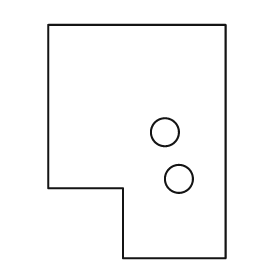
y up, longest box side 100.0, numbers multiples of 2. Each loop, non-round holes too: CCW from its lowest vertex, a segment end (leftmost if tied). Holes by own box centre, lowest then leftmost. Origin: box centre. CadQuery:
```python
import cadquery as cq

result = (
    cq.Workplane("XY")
    .moveTo(-6.0, -50.0)
    .lineTo(38.0, -50.0)
    .lineTo(38.0, 50.0)
    .lineTo(-38.0, 50.0)
    .lineTo(-38.0, -20.0)
    .lineTo(-6.0, -20.0)
    .close()
    .moveTo(18.0, -16.0)
    .circle(6.0)
    .moveTo(12.0, 4.0)
    .circle(6.0)
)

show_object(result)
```